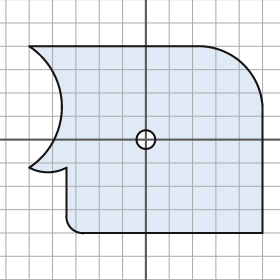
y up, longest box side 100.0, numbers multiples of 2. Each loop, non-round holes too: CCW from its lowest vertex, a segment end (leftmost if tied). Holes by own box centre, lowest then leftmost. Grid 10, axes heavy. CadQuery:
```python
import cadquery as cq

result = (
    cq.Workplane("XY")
    .moveTo(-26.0, -40.0)
    .lineTo(50.0, -40.0)
    .lineTo(50.0, 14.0)
    .threePointArc((42.0, 32.0), (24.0, 40.0))
    .lineTo(-50.0, 40.0)
    .threePointArc((-36.0, 14.0), (-50.0, -12.0))
    .threePointArc((-42.0, -14.0), (-34.0, -12.0))
    .lineTo(-34.0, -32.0)
    .threePointArc((-32.0, -38.0), (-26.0, -40.0))
    .close()
    .moveTo(0.0, 0.0)
    .circle(4.0)
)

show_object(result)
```